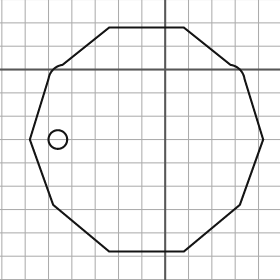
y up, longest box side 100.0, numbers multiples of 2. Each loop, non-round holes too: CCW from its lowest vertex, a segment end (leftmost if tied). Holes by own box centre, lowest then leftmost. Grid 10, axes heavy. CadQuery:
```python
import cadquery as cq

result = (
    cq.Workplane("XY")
    .moveTo(-24.0, -78.0)
    .lineTo(8.0, -78.0)
    .lineTo(32.0, -58.0)
    .lineTo(42.0, -30.0)
    .lineTo(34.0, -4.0)
    .threePointArc((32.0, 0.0), (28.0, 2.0))
    .lineTo(8.0, 18.0)
    .lineTo(-24.0, 18.0)
    .lineTo(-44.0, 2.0)
    .threePointArc((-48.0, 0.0), (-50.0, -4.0))
    .lineTo(-58.0, -30.0)
    .lineTo(-48.0, -58.0)
    .close()
    .moveTo(-46.0, -30.0)
    .circle(4.0)
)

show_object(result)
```